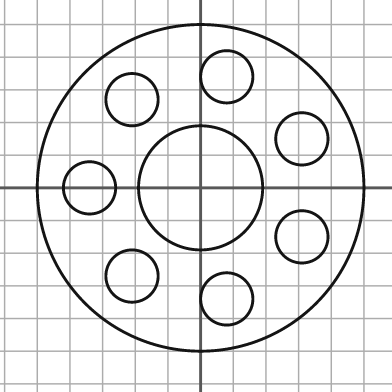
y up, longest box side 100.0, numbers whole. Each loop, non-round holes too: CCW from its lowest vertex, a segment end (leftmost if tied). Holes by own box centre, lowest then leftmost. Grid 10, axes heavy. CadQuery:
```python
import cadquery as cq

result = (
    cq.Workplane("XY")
    .moveTo(0.0, 0.0)
    .circle(50.0)
    .moveTo(8.0, -34.0)
    .circle(8.0)
    .moveTo(-21.0, -27.0)
    .circle(8.0)
    .moveTo(31.0, -15.0)
    .circle(8.0)
    .moveTo(-34.0, 0.0)
    .circle(8.0)
    .moveTo(0.0, 0.0)
    .circle(19.0)
    .moveTo(31.0, 15.0)
    .circle(8.0)
    .moveTo(-21.0, 27.0)
    .circle(8.0)
    .moveTo(8.0, 34.0)
    .circle(8.0)
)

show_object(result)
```